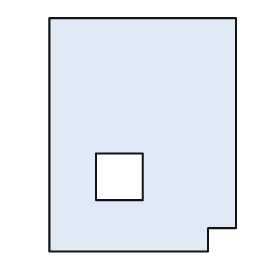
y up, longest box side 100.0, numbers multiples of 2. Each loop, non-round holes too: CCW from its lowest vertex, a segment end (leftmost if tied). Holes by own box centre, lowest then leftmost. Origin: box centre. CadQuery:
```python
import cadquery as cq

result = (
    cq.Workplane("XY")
    .moveTo(-40.0, -50.0)
    .lineTo(28.0, -50.0)
    .lineTo(28.0, -40.0)
    .lineTo(40.0, -40.0)
    .lineTo(40.0, 50.0)
    .lineTo(-40.0, 50.0)
    .close()
    .moveTo(-20.0, -28.0)
    .lineTo(0.0, -28.0)
    .lineTo(0.0, -8.0)
    .lineTo(-20.0, -8.0)
    .close()
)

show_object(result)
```